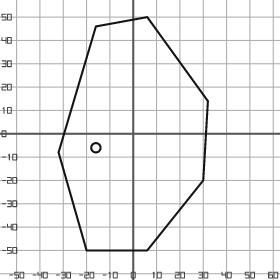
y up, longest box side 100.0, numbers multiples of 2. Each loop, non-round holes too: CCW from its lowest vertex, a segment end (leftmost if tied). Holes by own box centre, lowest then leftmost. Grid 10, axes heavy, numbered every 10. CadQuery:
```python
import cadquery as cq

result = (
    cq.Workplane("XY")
    .moveTo(-20.0, -50.0)
    .lineTo(6.0, -50.0)
    .lineTo(30.0, -20.0)
    .lineTo(32.0, 14.0)
    .lineTo(6.0, 50.0)
    .lineTo(-16.0, 46.0)
    .lineTo(-32.0, -8.0)
    .close()
    .moveTo(-16.0, -6.0)
    .circle(2.0)
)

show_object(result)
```